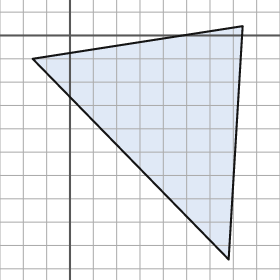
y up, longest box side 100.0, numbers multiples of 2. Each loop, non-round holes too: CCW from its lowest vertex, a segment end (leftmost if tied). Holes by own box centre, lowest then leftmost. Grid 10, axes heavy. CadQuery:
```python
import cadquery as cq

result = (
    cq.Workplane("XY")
    .moveTo(68.0, -96.0)
    .lineTo(74.0, 4.0)
    .lineTo(-16.0, -10.0)
    .close()
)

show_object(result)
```